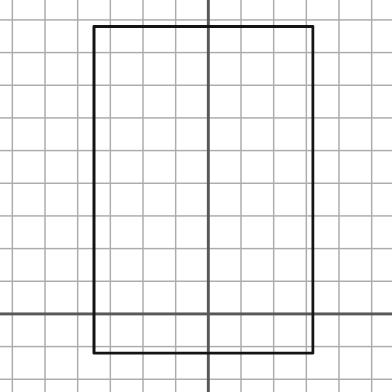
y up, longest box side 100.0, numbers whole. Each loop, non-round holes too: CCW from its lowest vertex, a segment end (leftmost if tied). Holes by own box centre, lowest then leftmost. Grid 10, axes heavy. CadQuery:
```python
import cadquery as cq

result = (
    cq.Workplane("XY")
    .moveTo(-35.0, -12.0)
    .lineTo(32.0, -12.0)
    .lineTo(32.0, 88.0)
    .lineTo(-35.0, 88.0)
    .close()
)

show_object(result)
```